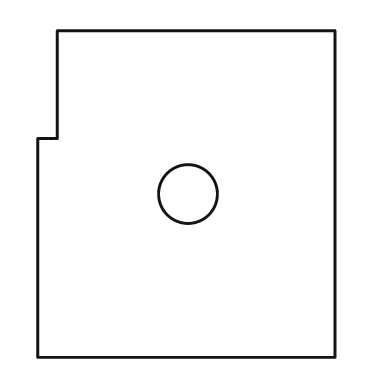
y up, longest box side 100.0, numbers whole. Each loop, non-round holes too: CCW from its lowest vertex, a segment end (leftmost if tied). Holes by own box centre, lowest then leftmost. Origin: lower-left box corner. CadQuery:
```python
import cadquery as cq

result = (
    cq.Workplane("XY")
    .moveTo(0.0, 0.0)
    .lineTo(91.0, 0.0)
    .lineTo(91.0, 100.0)
    .lineTo(6.0, 100.0)
    .lineTo(6.0, 67.0)
    .lineTo(0.0, 67.0)
    .close()
    .moveTo(46.0, 50.0)
    .circle(9.0)
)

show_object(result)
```